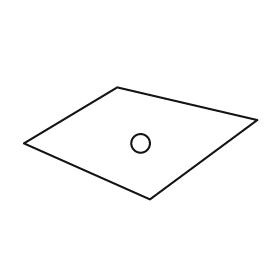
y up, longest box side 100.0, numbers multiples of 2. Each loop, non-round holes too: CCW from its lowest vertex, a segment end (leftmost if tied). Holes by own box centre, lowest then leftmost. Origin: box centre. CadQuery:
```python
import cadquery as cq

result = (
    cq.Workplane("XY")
    .moveTo(4.0, -24.0)
    .lineTo(50.0, 10.0)
    .lineTo(-10.0, 24.0)
    .lineTo(-50.0, 0.0)
    .close()
    .moveTo(0.0, 0.0)
    .circle(4.0)
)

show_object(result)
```